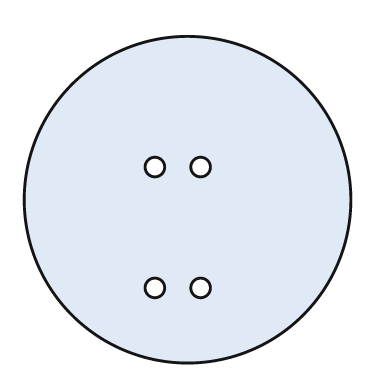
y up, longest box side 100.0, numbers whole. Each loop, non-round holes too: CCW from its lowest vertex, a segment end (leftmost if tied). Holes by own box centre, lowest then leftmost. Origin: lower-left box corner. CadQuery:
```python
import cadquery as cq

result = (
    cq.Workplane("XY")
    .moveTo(50.0, 50.0)
    .circle(50.0)
    .moveTo(40.0, 23.0)
    .circle(3.0)
    .moveTo(54.0, 23.0)
    .circle(3.0)
    .moveTo(40.0, 60.0)
    .circle(3.0)
    .moveTo(54.0, 60.0)
    .circle(3.0)
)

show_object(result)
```